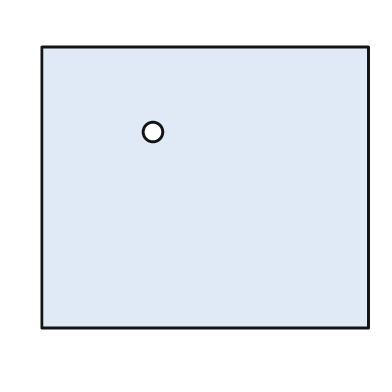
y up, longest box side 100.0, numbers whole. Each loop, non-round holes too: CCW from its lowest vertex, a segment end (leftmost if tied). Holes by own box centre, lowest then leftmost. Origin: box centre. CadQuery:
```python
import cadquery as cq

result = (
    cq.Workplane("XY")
    .moveTo(-50.0, -43.0)
    .lineTo(50.0, -43.0)
    .lineTo(50.0, 43.0)
    .lineTo(-50.0, 43.0)
    .close()
    .moveTo(-16.0, 17.0)
    .circle(3.0)
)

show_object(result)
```